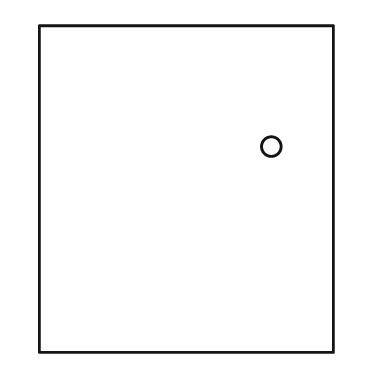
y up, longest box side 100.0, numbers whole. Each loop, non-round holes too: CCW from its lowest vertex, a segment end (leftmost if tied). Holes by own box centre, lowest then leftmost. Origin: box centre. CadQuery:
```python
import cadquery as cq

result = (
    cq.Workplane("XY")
    .moveTo(-45.0, -50.0)
    .lineTo(45.0, -50.0)
    .lineTo(45.0, 50.0)
    .lineTo(-45.0, 50.0)
    .close()
    .moveTo(26.0, 13.0)
    .circle(3.0)
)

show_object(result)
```